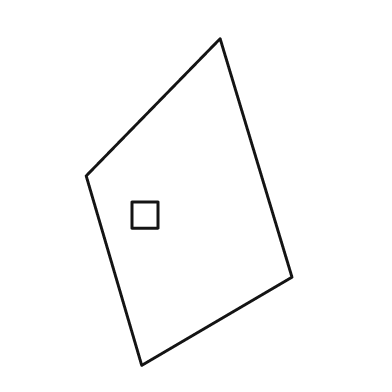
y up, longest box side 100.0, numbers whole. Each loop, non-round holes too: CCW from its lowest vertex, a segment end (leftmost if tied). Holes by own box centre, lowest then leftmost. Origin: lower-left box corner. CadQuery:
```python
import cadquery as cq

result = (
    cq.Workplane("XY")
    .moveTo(17.0, 0.0)
    .lineTo(63.0, 27.0)
    .lineTo(41.0, 100.0)
    .lineTo(0.0, 58.0)
    .close()
    .moveTo(14.0, 42.0)
    .lineTo(22.0, 42.0)
    .lineTo(22.0, 50.0)
    .lineTo(14.0, 50.0)
    .close()
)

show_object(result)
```